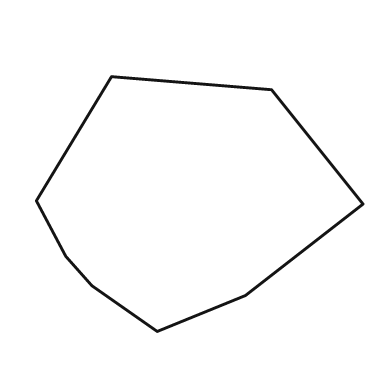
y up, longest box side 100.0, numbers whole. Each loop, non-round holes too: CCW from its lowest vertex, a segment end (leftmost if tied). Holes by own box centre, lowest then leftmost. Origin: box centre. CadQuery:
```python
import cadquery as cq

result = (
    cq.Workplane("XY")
    .moveTo(-13.0, -39.0)
    .lineTo(14.0, -28.0)
    .lineTo(50.0, 0.0)
    .lineTo(22.0, 35.0)
    .lineTo(-27.0, 39.0)
    .lineTo(-50.0, 1.0)
    .lineTo(-41.0, -16.0)
    .lineTo(-33.0, -25.0)
    .close()
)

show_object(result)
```